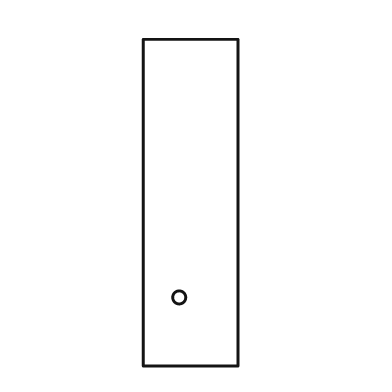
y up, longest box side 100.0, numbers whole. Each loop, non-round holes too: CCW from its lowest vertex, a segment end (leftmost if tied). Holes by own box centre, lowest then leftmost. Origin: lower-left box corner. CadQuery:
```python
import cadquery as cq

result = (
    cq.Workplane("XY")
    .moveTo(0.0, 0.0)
    .lineTo(29.0, 0.0)
    .lineTo(29.0, 100.0)
    .lineTo(0.0, 100.0)
    .close()
    .moveTo(11.0, 21.0)
    .circle(2.0)
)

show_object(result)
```